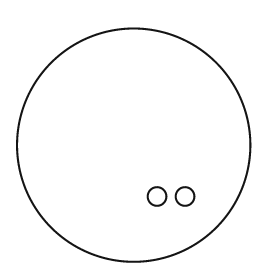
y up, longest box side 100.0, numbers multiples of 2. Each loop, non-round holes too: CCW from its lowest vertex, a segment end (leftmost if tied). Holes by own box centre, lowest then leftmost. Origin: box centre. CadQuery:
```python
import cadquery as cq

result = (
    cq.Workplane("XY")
    .moveTo(0.0, 0.0)
    .circle(50.0)
    .moveTo(10.0, -22.0)
    .circle(4.0)
    .moveTo(22.0, -22.0)
    .circle(4.0)
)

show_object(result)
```